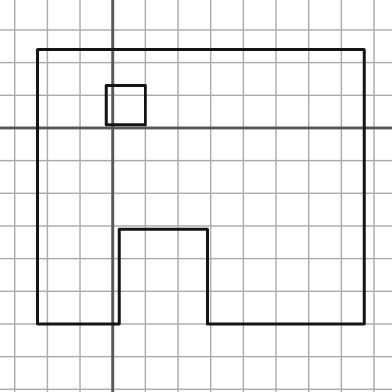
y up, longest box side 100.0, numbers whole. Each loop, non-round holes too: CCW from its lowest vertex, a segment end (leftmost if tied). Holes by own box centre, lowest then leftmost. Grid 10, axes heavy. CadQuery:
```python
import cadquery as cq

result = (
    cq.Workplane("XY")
    .moveTo(-23.0, -60.0)
    .lineTo(2.0, -60.0)
    .lineTo(2.0, -31.0)
    .lineTo(29.0, -31.0)
    .lineTo(29.0, -60.0)
    .lineTo(77.0, -60.0)
    .lineTo(77.0, 24.0)
    .lineTo(-23.0, 24.0)
    .close()
    .moveTo(-2.0, 1.0)
    .lineTo(10.0, 1.0)
    .lineTo(10.0, 13.0)
    .lineTo(-2.0, 13.0)
    .close()
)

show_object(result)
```